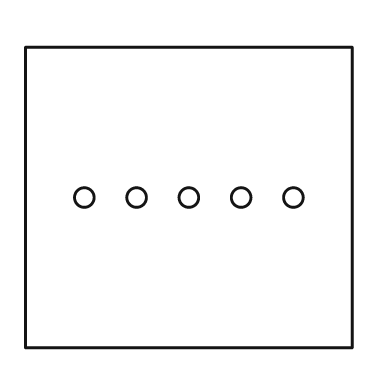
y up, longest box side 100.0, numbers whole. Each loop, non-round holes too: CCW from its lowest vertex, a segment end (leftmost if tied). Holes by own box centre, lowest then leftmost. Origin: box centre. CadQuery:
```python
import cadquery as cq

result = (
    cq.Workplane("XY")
    .moveTo(-50.0, -46.0)
    .lineTo(50.0, -46.0)
    .lineTo(50.0, 46.0)
    .lineTo(-50.0, 46.0)
    .close()
    .moveTo(-32.0, 0.0)
    .circle(3.0)
    .moveTo(-16.0, 0.0)
    .circle(3.0)
    .moveTo(0.0, 0.0)
    .circle(3.0)
    .moveTo(16.0, 0.0)
    .circle(3.0)
    .moveTo(32.0, 0.0)
    .circle(3.0)
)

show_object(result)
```